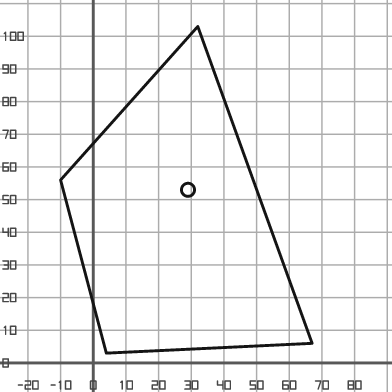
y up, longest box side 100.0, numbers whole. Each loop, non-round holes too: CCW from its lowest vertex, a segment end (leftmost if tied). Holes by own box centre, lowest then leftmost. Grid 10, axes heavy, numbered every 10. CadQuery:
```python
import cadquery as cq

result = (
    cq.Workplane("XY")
    .moveTo(4.0, 3.0)
    .lineTo(67.0, 6.0)
    .lineTo(32.0, 103.0)
    .lineTo(-10.0, 56.0)
    .close()
    .moveTo(29.0, 53.0)
    .circle(2.0)
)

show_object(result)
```